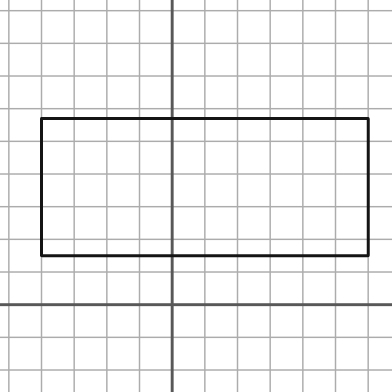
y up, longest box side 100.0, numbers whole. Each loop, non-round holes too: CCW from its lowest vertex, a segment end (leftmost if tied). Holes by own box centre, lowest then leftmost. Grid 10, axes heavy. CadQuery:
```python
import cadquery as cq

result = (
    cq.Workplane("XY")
    .moveTo(-40.0, 15.0)
    .lineTo(60.0, 15.0)
    .lineTo(60.0, 57.0)
    .lineTo(-40.0, 57.0)
    .close()
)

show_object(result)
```